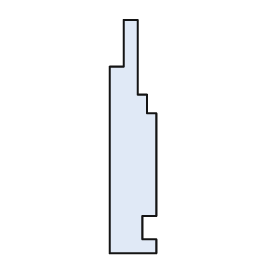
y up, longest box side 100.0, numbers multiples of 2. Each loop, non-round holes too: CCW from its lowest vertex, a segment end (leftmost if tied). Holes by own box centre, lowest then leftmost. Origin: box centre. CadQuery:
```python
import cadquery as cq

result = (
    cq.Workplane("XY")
    .moveTo(-10.0, -50.0)
    .lineTo(10.0, -50.0)
    .lineTo(10.0, -44.0)
    .lineTo(4.0, -44.0)
    .lineTo(4.0, -34.0)
    .lineTo(10.0, -34.0)
    .lineTo(10.0, 10.0)
    .lineTo(6.0, 10.0)
    .lineTo(6.0, 18.0)
    .lineTo(2.0, 18.0)
    .lineTo(2.0, 50.0)
    .lineTo(-4.0, 50.0)
    .lineTo(-4.0, 30.0)
    .lineTo(-10.0, 30.0)
    .close()
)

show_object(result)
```